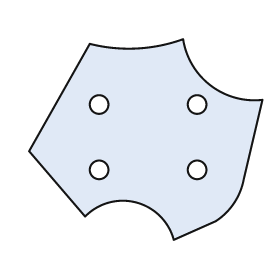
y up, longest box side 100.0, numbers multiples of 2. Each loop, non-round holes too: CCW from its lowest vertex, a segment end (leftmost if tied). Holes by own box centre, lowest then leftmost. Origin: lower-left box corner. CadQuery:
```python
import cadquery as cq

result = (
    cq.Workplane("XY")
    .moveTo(62.0, 0.0)
    .lineTo(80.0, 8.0)
    .threePointArc((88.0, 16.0), (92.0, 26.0))
    .lineTo(100.0, 60.0)
    .threePointArc((78.0, 66.0), (66.0, 86.0))
    .threePointArc((46.0, 82.0), (26.0, 84.0))
    .lineTo(0.0, 38.0)
    .lineTo(24.0, 10.0)
    .threePointArc((46.0, 16.0), (62.0, 0.0))
    .close()
    .moveTo(30.0, 30.0)
    .circle(4.0)
    .moveTo(72.0, 30.0)
    .circle(4.0)
    .moveTo(30.0, 58.0)
    .circle(4.0)
    .moveTo(72.0, 58.0)
    .circle(4.0)
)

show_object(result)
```